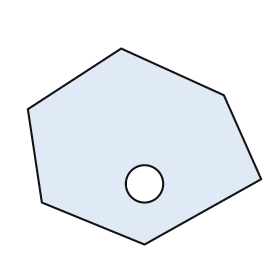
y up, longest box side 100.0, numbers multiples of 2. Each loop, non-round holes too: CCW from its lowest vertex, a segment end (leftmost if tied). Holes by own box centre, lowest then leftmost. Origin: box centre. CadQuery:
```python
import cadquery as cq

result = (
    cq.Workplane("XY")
    .moveTo(0.0, -42.0)
    .lineTo(50.0, -14.0)
    .lineTo(34.0, 22.0)
    .lineTo(-10.0, 42.0)
    .lineTo(-50.0, 16.0)
    .lineTo(-44.0, -24.0)
    .close()
    .moveTo(0.0, -16.0)
    .circle(8.0)
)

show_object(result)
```